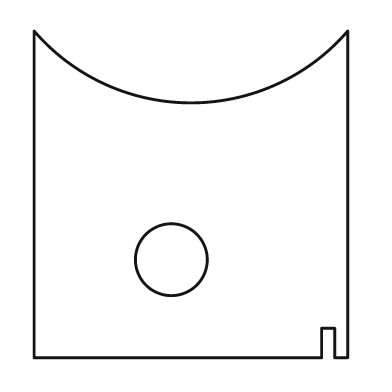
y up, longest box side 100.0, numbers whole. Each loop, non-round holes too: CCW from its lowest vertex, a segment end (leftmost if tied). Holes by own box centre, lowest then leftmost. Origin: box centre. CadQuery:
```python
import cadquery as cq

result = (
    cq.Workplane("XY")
    .moveTo(-48.0, -50.0)
    .lineTo(40.0, -50.0)
    .lineTo(40.0, -41.0)
    .lineTo(44.0, -41.0)
    .lineTo(44.0, -50.0)
    .lineTo(48.0, -50.0)
    .lineTo(48.0, 50.0)
    .threePointArc((0.0, 28.0), (-48.0, 50.0))
    .close()
    .moveTo(-6.0, -20.0)
    .circle(11.0)
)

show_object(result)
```